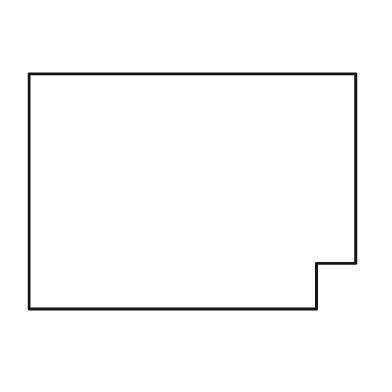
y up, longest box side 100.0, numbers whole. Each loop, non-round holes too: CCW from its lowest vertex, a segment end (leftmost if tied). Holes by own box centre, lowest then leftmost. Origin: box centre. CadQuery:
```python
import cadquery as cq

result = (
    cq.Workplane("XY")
    .moveTo(-50.0, -36.0)
    .lineTo(38.0, -36.0)
    .lineTo(38.0, -22.0)
    .lineTo(50.0, -22.0)
    .lineTo(50.0, 36.0)
    .lineTo(-50.0, 36.0)
    .close()
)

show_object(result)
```